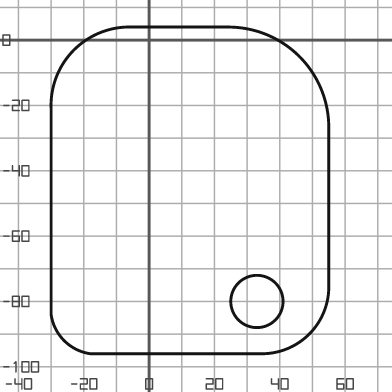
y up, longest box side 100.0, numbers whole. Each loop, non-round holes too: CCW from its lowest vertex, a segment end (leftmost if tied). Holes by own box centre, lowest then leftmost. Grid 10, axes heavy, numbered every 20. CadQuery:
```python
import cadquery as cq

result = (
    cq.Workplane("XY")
    .moveTo(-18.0, -96.0)
    .lineTo(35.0, -96.0)
    .threePointArc((49.0, -90.0), (55.0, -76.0))
    .lineTo(55.0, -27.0)
    .threePointArc((46.0, -5.0), (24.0, 4.0))
    .lineTo(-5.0, 4.0)
    .threePointArc((-23.0, -3.0), (-30.0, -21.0))
    .lineTo(-30.0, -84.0)
    .threePointArc((-26.0, -92.0), (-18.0, -96.0))
    .close()
    .moveTo(33.0, -80.0)
    .circle(8.0)
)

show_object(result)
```